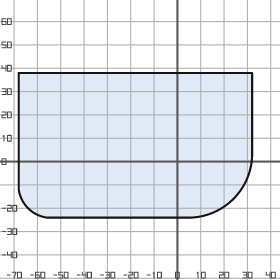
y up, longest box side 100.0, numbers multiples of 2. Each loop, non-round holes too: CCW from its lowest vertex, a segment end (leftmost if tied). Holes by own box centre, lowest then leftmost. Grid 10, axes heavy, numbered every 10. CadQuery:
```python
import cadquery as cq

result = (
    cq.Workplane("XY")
    .moveTo(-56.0, -24.0)
    .lineTo(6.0, -24.0)
    .threePointArc((24.0, -16.0), (32.0, 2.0))
    .lineTo(32.0, 38.0)
    .lineTo(-68.0, 38.0)
    .lineTo(-68.0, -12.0)
    .threePointArc((-64.0, -20.0), (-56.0, -24.0))
    .close()
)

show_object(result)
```